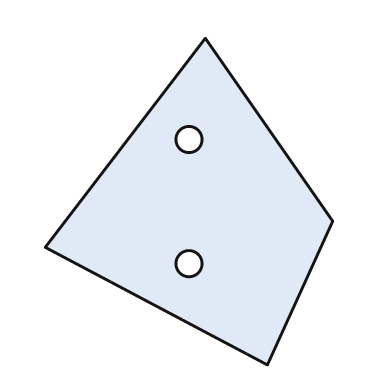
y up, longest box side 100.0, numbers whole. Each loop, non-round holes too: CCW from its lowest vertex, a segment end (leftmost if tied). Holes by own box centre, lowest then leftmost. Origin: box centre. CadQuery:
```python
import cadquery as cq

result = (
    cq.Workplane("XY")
    .moveTo(24.0, -50.0)
    .lineTo(44.0, -6.0)
    .lineTo(5.0, 50.0)
    .lineTo(-44.0, -14.0)
    .close()
    .moveTo(0.0, -19.0)
    .circle(4.0)
    .moveTo(0.0, 19.0)
    .circle(4.0)
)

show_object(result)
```